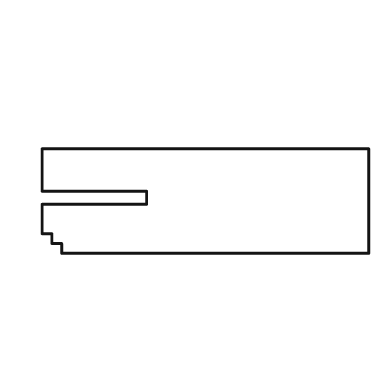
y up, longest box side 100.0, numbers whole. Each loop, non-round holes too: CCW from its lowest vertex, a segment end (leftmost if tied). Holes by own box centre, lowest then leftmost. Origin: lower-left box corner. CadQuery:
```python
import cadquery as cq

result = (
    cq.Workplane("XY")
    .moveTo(6.0, 0.0)
    .lineTo(100.0, 0.0)
    .lineTo(100.0, 32.0)
    .lineTo(0.0, 32.0)
    .lineTo(0.0, 19.0)
    .lineTo(32.0, 19.0)
    .lineTo(32.0, 15.0)
    .lineTo(0.0, 15.0)
    .lineTo(0.0, 6.0)
    .lineTo(3.0, 6.0)
    .lineTo(3.0, 3.0)
    .lineTo(6.0, 3.0)
    .close()
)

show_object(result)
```